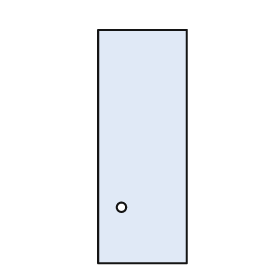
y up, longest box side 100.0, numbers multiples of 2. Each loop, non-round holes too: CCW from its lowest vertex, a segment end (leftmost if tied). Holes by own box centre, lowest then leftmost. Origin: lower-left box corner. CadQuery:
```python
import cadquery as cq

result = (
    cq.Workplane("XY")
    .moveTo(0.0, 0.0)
    .lineTo(38.0, 0.0)
    .lineTo(38.0, 100.0)
    .lineTo(0.0, 100.0)
    .close()
    .moveTo(10.0, 24.0)
    .circle(2.0)
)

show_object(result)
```